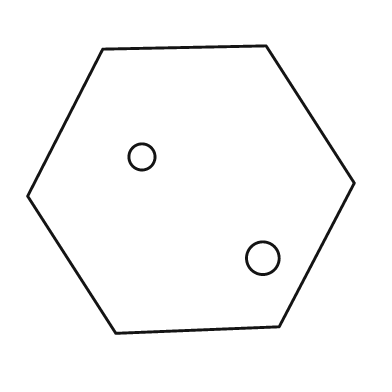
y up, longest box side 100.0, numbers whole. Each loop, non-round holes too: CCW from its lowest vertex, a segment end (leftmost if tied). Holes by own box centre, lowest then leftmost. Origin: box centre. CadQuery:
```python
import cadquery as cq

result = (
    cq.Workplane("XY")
    .moveTo(-23.0, -44.0)
    .lineTo(27.0, -42.0)
    .lineTo(50.0, 2.0)
    .lineTo(23.0, 44.0)
    .lineTo(-27.0, 43.0)
    .lineTo(-50.0, -2.0)
    .close()
    .moveTo(22.0, -21.0)
    .circle(5.0)
    .moveTo(-15.0, 10.0)
    .circle(4.0)
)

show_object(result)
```